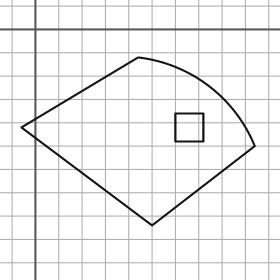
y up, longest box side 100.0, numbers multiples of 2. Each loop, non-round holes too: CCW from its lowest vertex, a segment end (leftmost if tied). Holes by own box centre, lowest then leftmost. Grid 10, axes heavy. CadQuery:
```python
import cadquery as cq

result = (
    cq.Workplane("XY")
    .moveTo(50.0, -84.0)
    .lineTo(94.0, -50.0)
    .threePointArc((74.0, -24.0), (44.0, -12.0))
    .lineTo(-6.0, -42.0)
    .close()
    .moveTo(60.0, -48.0)
    .lineTo(72.0, -48.0)
    .lineTo(72.0, -36.0)
    .lineTo(60.0, -36.0)
    .close()
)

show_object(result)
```